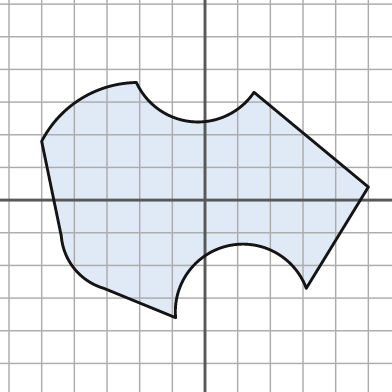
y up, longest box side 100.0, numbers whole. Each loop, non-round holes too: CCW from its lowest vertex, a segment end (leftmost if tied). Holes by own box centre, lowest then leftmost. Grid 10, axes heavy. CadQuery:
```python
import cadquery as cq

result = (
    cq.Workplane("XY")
    .moveTo(-9.0, -36.0)
    .threePointArc((7.0, -14.0), (31.0, -27.0))
    .lineTo(50.0, 4.0)
    .lineTo(15.0, 33.0)
    .threePointArc((-4.0, 24.0), (-21.0, 36.0))
    .threePointArc((-38.0, 31.0), (-50.0, 18.0))
    .lineTo(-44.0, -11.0)
    .threePointArc((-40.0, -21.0), (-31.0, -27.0))
    .close()
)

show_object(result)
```